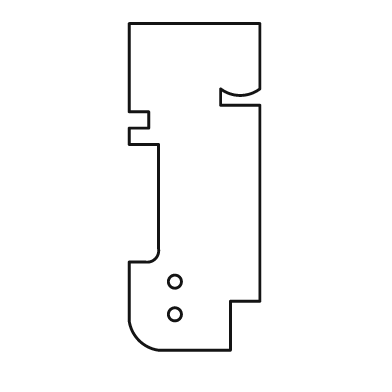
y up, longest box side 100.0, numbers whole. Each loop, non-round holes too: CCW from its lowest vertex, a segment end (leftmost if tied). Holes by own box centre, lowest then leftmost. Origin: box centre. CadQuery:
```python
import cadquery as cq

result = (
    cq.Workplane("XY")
    .moveTo(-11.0, -50.0)
    .lineTo(11.0, -50.0)
    .lineTo(11.0, -35.0)
    .lineTo(20.0, -35.0)
    .lineTo(20.0, 25.0)
    .lineTo(8.0, 25.0)
    .lineTo(8.0, 30.0)
    .threePointArc((14.0, 28.0), (20.0, 30.0))
    .lineTo(20.0, 50.0)
    .lineTo(-20.0, 50.0)
    .lineTo(-20.0, 23.0)
    .lineTo(-14.0, 23.0)
    .lineTo(-14.0, 18.0)
    .lineTo(-20.0, 18.0)
    .lineTo(-20.0, 13.0)
    .lineTo(-11.0, 13.0)
    .lineTo(-11.0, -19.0)
    .threePointArc((-12.0, -22.0), (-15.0, -23.0))
    .lineTo(-20.0, -23.0)
    .lineTo(-20.0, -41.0)
    .threePointArc((-17.0, -47.0), (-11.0, -50.0))
    .close()
    .moveTo(-6.0, -39.0)
    .circle(2.0)
    .moveTo(-6.0, -29.0)
    .circle(2.0)
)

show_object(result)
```